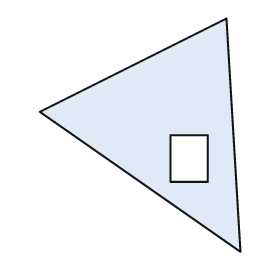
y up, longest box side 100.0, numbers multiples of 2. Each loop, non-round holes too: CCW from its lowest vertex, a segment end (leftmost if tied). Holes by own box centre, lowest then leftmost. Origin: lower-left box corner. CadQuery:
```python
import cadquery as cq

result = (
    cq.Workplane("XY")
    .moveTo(86.0, 0.0)
    .lineTo(80.0, 100.0)
    .lineTo(0.0, 60.0)
    .close()
    .moveTo(56.0, 30.0)
    .lineTo(72.0, 30.0)
    .lineTo(72.0, 50.0)
    .lineTo(56.0, 50.0)
    .close()
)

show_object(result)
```